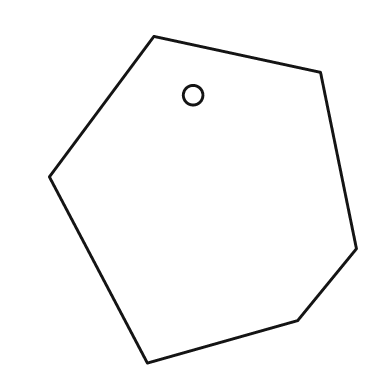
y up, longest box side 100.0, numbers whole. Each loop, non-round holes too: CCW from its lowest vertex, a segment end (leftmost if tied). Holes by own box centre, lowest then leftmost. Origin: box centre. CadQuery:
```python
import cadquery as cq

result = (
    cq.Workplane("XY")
    .moveTo(-17.0, -50.0)
    .lineTo(29.0, -37.0)
    .lineTo(47.0, -15.0)
    .lineTo(36.0, 39.0)
    .lineTo(-15.0, 50.0)
    .lineTo(-47.0, 7.0)
    .close()
    .moveTo(-3.0, 32.0)
    .circle(3.0)
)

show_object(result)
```